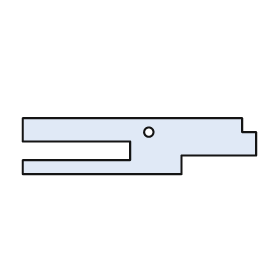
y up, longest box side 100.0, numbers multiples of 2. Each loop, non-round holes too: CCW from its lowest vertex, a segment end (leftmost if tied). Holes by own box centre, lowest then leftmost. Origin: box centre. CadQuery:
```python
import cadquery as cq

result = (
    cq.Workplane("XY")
    .moveTo(-50.0, -12.0)
    .lineTo(18.0, -12.0)
    .lineTo(18.0, -4.0)
    .lineTo(50.0, -4.0)
    .lineTo(50.0, 6.0)
    .lineTo(44.0, 6.0)
    .lineTo(44.0, 12.0)
    .lineTo(-50.0, 12.0)
    .lineTo(-50.0, 2.0)
    .lineTo(-4.0, 2.0)
    .lineTo(-4.0, -6.0)
    .lineTo(-50.0, -6.0)
    .close()
    .moveTo(4.0, 6.0)
    .circle(2.0)
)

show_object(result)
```